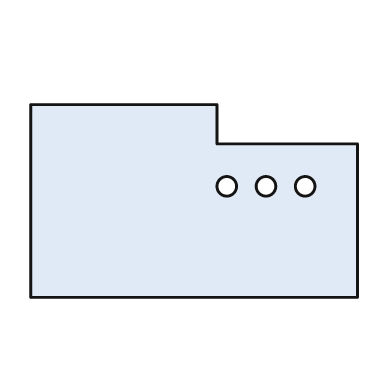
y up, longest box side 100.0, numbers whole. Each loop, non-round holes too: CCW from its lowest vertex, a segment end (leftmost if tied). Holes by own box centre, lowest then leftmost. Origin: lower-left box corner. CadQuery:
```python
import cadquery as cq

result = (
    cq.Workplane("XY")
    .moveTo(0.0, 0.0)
    .lineTo(100.0, 0.0)
    .lineTo(100.0, 47.0)
    .lineTo(57.0, 47.0)
    .lineTo(57.0, 59.0)
    .lineTo(0.0, 59.0)
    .close()
    .moveTo(60.0, 34.0)
    .circle(3.0)
    .moveTo(72.0, 34.0)
    .circle(3.0)
    .moveTo(84.0, 34.0)
    .circle(3.0)
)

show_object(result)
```